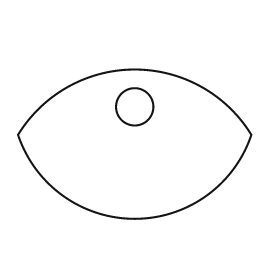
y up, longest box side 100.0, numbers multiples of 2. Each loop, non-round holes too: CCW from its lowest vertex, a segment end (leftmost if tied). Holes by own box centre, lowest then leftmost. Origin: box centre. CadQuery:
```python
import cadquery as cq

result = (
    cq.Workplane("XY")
    .moveTo(-50.0, 4.0)
    .threePointArc((0.0, -32.0), (50.0, 4.0))
    .threePointArc((0.0, 32.0), (-50.0, 4.0))
    .close()
    .moveTo(0.0, 16.0)
    .circle(8.0)
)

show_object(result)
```